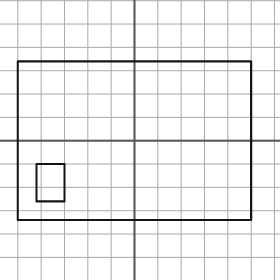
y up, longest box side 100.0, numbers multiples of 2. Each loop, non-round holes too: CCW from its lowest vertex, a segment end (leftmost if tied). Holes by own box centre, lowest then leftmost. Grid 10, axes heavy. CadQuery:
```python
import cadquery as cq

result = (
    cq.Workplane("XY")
    .moveTo(-50.0, -34.0)
    .lineTo(50.0, -34.0)
    .lineTo(50.0, 34.0)
    .lineTo(-50.0, 34.0)
    .close()
    .moveTo(-42.0, -26.0)
    .lineTo(-30.0, -26.0)
    .lineTo(-30.0, -10.0)
    .lineTo(-42.0, -10.0)
    .close()
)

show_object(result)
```